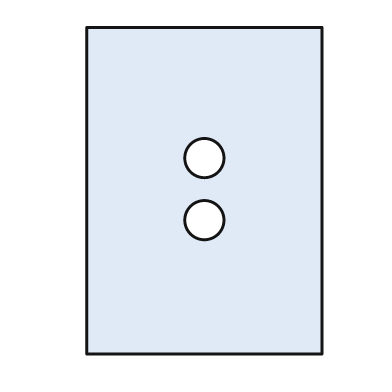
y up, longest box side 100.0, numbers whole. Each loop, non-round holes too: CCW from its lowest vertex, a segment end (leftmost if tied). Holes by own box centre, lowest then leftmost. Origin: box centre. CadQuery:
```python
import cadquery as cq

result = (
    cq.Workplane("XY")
    .moveTo(-36.0, -50.0)
    .lineTo(36.0, -50.0)
    .lineTo(36.0, 50.0)
    .lineTo(-36.0, 50.0)
    .close()
    .moveTo(0.0, -9.0)
    .circle(6.0)
    .moveTo(0.0, 10.0)
    .circle(6.0)
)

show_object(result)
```